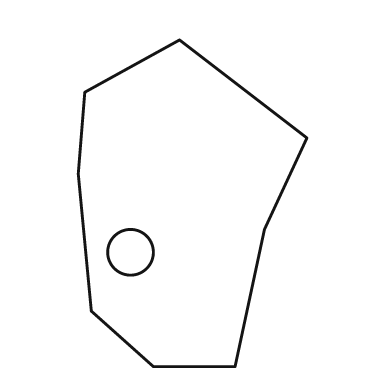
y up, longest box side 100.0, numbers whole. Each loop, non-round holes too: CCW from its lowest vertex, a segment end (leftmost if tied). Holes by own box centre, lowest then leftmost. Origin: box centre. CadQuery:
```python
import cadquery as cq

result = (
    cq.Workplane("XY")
    .moveTo(-12.0, -50.0)
    .lineTo(13.0, -50.0)
    .lineTo(22.0, -8.0)
    .lineTo(35.0, 20.0)
    .lineTo(-4.0, 50.0)
    .lineTo(-33.0, 34.0)
    .lineTo(-35.0, 9.0)
    .lineTo(-31.0, -33.0)
    .close()
    .moveTo(-19.0, -15.0)
    .circle(7.0)
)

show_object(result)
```